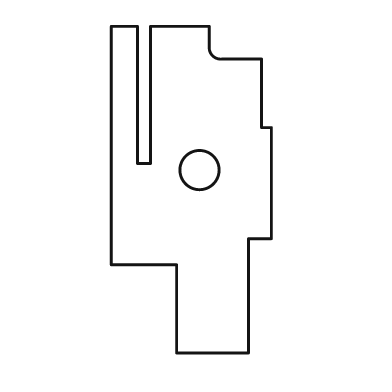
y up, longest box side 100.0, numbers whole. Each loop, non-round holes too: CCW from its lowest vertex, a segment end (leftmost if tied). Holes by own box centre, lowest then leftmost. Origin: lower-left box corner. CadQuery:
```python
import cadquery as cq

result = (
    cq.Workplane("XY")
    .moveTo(20.0, 0.0)
    .lineTo(42.0, 0.0)
    .lineTo(42.0, 35.0)
    .lineTo(49.0, 35.0)
    .lineTo(49.0, 69.0)
    .lineTo(46.0, 69.0)
    .lineTo(46.0, 90.0)
    .lineTo(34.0, 90.0)
    .threePointArc((31.0, 91.0), (30.0, 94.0))
    .lineTo(30.0, 100.0)
    .lineTo(12.0, 100.0)
    .lineTo(12.0, 58.0)
    .lineTo(8.0, 58.0)
    .lineTo(8.0, 100.0)
    .lineTo(0.0, 100.0)
    .lineTo(0.0, 27.0)
    .lineTo(20.0, 27.0)
    .close()
    .moveTo(27.0, 56.0)
    .circle(6.0)
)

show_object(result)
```